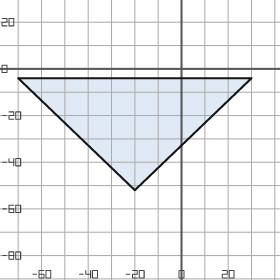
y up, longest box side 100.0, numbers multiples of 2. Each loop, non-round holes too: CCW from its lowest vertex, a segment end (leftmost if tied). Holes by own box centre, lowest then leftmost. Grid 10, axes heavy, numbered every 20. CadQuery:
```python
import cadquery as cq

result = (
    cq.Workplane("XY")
    .moveTo(-20.0, -52.0)
    .lineTo(30.0, -4.0)
    .lineTo(-70.0, -4.0)
    .close()
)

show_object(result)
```